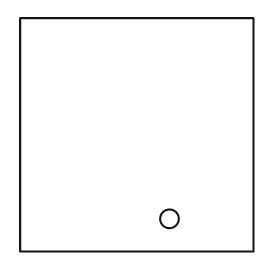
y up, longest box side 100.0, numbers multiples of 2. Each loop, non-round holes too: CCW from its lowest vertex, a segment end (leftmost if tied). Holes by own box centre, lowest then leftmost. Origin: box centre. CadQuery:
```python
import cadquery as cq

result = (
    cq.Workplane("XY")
    .moveTo(-50.0, -50.0)
    .lineTo(50.0, -50.0)
    .lineTo(50.0, 50.0)
    .lineTo(-50.0, 50.0)
    .close()
    .moveTo(14.0, -36.0)
    .circle(4.0)
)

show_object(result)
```